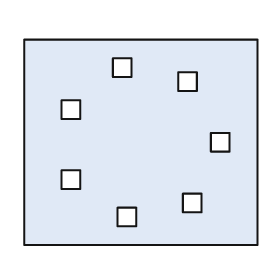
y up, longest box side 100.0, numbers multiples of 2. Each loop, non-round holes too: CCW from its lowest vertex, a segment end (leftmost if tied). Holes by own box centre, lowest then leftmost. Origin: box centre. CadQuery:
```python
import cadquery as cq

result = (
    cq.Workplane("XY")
    .moveTo(-50.0, -44.0)
    .lineTo(50.0, -44.0)
    .lineTo(50.0, 44.0)
    .lineTo(-50.0, 44.0)
    .close()
    .moveTo(-10.0, -36.0)
    .lineTo(-2.0, -36.0)
    .lineTo(-2.0, -28.0)
    .lineTo(-10.0, -28.0)
    .close()
    .moveTo(18.0, -30.0)
    .lineTo(26.0, -30.0)
    .lineTo(26.0, -22.0)
    .lineTo(18.0, -22.0)
    .close()
    .moveTo(-34.0, -20.0)
    .lineTo(-26.0, -20.0)
    .lineTo(-26.0, -12.0)
    .lineTo(-34.0, -12.0)
    .close()
    .moveTo(30.0, -4.0)
    .lineTo(38.0, -4.0)
    .lineTo(38.0, 4.0)
    .lineTo(30.0, 4.0)
    .close()
    .moveTo(-34.0, 10.0)
    .lineTo(-26.0, 10.0)
    .lineTo(-26.0, 18.0)
    .lineTo(-34.0, 18.0)
    .close()
    .moveTo(16.0, 22.0)
    .lineTo(24.0, 22.0)
    .lineTo(24.0, 30.0)
    .lineTo(16.0, 30.0)
    .close()
    .moveTo(-12.0, 28.0)
    .lineTo(-4.0, 28.0)
    .lineTo(-4.0, 36.0)
    .lineTo(-12.0, 36.0)
    .close()
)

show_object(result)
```